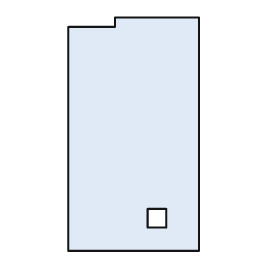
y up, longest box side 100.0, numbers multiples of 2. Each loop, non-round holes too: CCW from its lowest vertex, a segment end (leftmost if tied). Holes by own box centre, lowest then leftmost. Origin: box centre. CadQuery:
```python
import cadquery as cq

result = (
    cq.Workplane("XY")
    .moveTo(-28.0, -50.0)
    .lineTo(28.0, -50.0)
    .lineTo(28.0, 50.0)
    .lineTo(-8.0, 50.0)
    .lineTo(-8.0, 46.0)
    .lineTo(-28.0, 46.0)
    .close()
    .moveTo(6.0, -40.0)
    .lineTo(14.0, -40.0)
    .lineTo(14.0, -32.0)
    .lineTo(6.0, -32.0)
    .close()
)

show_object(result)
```